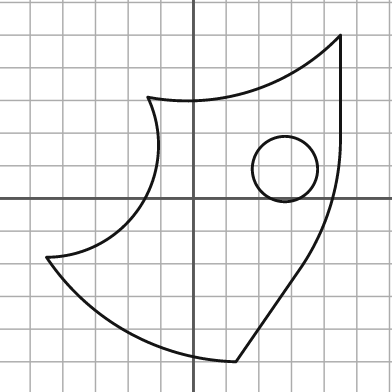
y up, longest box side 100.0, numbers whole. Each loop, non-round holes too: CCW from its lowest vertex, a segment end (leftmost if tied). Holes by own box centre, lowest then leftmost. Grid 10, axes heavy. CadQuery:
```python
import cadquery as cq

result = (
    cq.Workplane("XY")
    .moveTo(13.0, -50.0)
    .lineTo(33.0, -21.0)
    .threePointArc((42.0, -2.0), (45.0, 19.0))
    .lineTo(45.0, 50.0)
    .threePointArc((18.0, 33.0), (-14.0, 31.0))
    .threePointArc((-16.0, -2.0), (-45.0, -18.0))
    .threePointArc((-20.0, -41.0), (13.0, -50.0))
    .close()
    .moveTo(28.0, 9.0)
    .circle(10.0)
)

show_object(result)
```